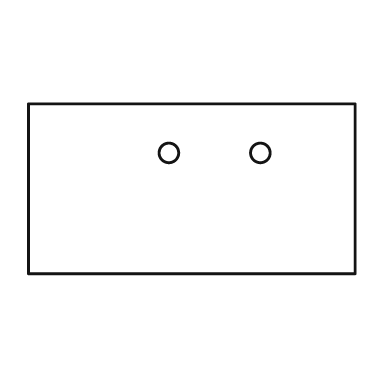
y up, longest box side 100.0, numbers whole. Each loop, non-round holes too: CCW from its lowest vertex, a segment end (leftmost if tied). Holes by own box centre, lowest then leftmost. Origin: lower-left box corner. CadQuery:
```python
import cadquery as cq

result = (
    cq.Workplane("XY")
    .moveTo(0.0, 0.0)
    .lineTo(100.0, 0.0)
    .lineTo(100.0, 52.0)
    .lineTo(0.0, 52.0)
    .close()
    .moveTo(43.0, 37.0)
    .circle(3.0)
    .moveTo(71.0, 37.0)
    .circle(3.0)
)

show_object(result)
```